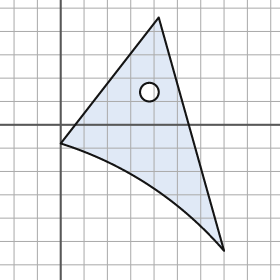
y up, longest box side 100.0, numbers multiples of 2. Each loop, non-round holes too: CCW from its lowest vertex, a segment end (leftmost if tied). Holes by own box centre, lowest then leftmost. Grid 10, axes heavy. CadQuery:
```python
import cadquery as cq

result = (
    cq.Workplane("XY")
    .moveTo(70.0, -54.0)
    .lineTo(42.0, 46.0)
    .lineTo(0.0, -8.0)
    .threePointArc((38.0, -26.0), (70.0, -54.0))
    .close()
    .moveTo(38.0, 14.0)
    .circle(4.0)
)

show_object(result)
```